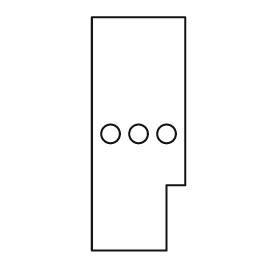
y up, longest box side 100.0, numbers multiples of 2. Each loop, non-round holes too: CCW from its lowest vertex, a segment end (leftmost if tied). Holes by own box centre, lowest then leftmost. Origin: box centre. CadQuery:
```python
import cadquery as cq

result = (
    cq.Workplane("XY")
    .moveTo(-20.0, -50.0)
    .lineTo(12.0, -50.0)
    .lineTo(12.0, -22.0)
    .lineTo(20.0, -22.0)
    .lineTo(20.0, 50.0)
    .lineTo(-20.0, 50.0)
    .close()
    .moveTo(-12.0, 0.0)
    .circle(4.0)
    .moveTo(0.0, 0.0)
    .circle(4.0)
    .moveTo(12.0, 0.0)
    .circle(4.0)
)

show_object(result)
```